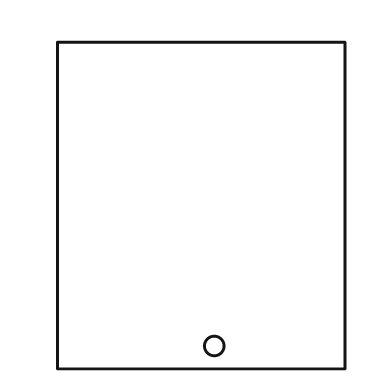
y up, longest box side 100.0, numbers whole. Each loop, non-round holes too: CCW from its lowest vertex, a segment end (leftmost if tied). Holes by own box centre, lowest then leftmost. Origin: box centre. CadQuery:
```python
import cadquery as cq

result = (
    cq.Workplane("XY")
    .moveTo(-44.0, -50.0)
    .lineTo(44.0, -50.0)
    .lineTo(44.0, 50.0)
    .lineTo(-44.0, 50.0)
    .close()
    .moveTo(4.0, -43.0)
    .circle(3.0)
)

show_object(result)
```